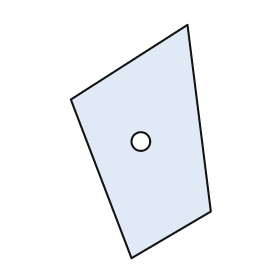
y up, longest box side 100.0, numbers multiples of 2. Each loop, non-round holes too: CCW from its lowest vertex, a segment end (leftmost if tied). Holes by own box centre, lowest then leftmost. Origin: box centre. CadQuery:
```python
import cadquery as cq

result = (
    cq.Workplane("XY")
    .moveTo(-4.0, -50.0)
    .lineTo(30.0, -30.0)
    .lineTo(20.0, 50.0)
    .lineTo(-30.0, 18.0)
    .close()
    .moveTo(0.0, 0.0)
    .circle(4.0)
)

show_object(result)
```